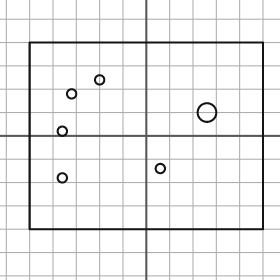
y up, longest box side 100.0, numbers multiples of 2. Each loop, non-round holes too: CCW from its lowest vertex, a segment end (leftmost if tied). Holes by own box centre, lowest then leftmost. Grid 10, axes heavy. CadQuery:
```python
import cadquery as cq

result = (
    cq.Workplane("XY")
    .moveTo(-50.0, -40.0)
    .lineTo(50.0, -40.0)
    .lineTo(50.0, 40.0)
    .lineTo(-50.0, 40.0)
    .close()
    .moveTo(-36.0, -18.0)
    .circle(2.0)
    .moveTo(6.0, -14.0)
    .circle(2.0)
    .moveTo(-36.0, 2.0)
    .circle(2.0)
    .moveTo(26.0, 10.0)
    .circle(4.0)
    .moveTo(-32.0, 18.0)
    .circle(2.0)
    .moveTo(-20.0, 24.0)
    .circle(2.0)
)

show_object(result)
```